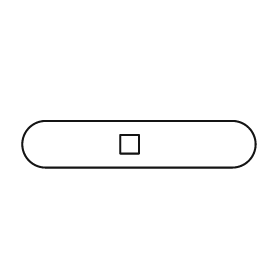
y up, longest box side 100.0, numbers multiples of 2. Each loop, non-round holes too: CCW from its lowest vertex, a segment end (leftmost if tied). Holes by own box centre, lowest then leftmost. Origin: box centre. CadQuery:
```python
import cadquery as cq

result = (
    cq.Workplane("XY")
    .moveTo(-40.0, -10.0)
    .lineTo(40.0, -10.0)
    .threePointArc((50.0, 0.0), (40.0, 10.0))
    .lineTo(-40.0, 10.0)
    .threePointArc((-50.0, 0.0), (-40.0, -10.0))
    .close()
    .moveTo(-8.0, -4.0)
    .lineTo(0.0, -4.0)
    .lineTo(0.0, 4.0)
    .lineTo(-8.0, 4.0)
    .close()
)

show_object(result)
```